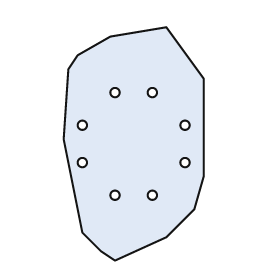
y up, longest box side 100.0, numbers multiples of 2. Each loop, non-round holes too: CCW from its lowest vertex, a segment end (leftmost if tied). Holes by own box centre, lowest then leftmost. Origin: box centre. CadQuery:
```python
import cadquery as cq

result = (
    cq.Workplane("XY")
    .moveTo(-8.0, -50.0)
    .lineTo(14.0, -40.0)
    .lineTo(26.0, -28.0)
    .lineTo(30.0, -14.0)
    .lineTo(30.0, 28.0)
    .lineTo(14.0, 50.0)
    .lineTo(-10.0, 46.0)
    .lineTo(-24.0, 38.0)
    .lineTo(-28.0, 32.0)
    .lineTo(-30.0, 2.0)
    .lineTo(-22.0, -38.0)
    .lineTo(-14.0, -46.0)
    .close()
    .moveTo(-8.0, -22.0)
    .circle(2.0)
    .moveTo(8.0, -22.0)
    .circle(2.0)
    .moveTo(-22.0, -8.0)
    .circle(2.0)
    .moveTo(22.0, -8.0)
    .circle(2.0)
    .moveTo(-22.0, 8.0)
    .circle(2.0)
    .moveTo(22.0, 8.0)
    .circle(2.0)
    .moveTo(-8.0, 22.0)
    .circle(2.0)
    .moveTo(8.0, 22.0)
    .circle(2.0)
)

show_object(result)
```